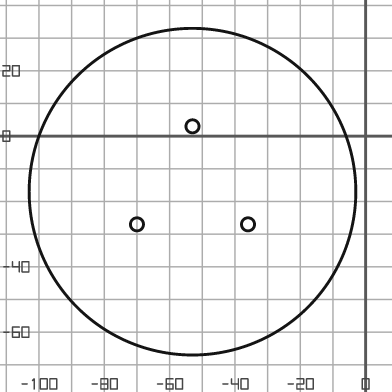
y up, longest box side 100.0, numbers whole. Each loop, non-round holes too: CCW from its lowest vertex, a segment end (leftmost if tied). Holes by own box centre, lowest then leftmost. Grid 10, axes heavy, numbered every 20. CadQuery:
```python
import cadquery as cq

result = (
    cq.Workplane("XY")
    .moveTo(-53.0, -17.0)
    .circle(50.0)
    .moveTo(-70.0, -27.0)
    .circle(2.0)
    .moveTo(-36.0, -27.0)
    .circle(2.0)
    .moveTo(-53.0, 3.0)
    .circle(2.0)
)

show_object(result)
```